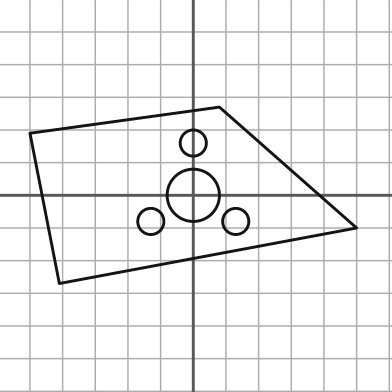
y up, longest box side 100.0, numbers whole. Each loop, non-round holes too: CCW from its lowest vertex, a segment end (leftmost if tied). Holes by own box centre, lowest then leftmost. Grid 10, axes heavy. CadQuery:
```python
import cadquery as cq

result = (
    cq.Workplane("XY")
    .moveTo(-41.0, -27.0)
    .lineTo(50.0, -10.0)
    .lineTo(8.0, 27.0)
    .lineTo(-50.0, 19.0)
    .close()
    .moveTo(-13.0, -8.0)
    .circle(4.0)
    .moveTo(13.0, -8.0)
    .circle(4.0)
    .moveTo(0.0, 0.0)
    .circle(8.0)
    .moveTo(0.0, 16.0)
    .circle(4.0)
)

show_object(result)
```